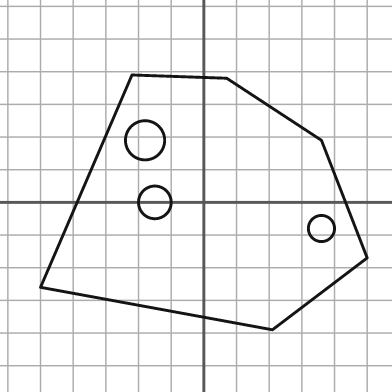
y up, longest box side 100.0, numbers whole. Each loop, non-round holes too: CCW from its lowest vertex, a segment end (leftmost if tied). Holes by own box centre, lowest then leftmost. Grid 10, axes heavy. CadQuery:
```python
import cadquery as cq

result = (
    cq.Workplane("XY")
    .moveTo(21.0, -39.0)
    .lineTo(50.0, -17.0)
    .lineTo(36.0, 19.0)
    .lineTo(7.0, 38.0)
    .lineTo(-22.0, 39.0)
    .lineTo(-50.0, -26.0)
    .close()
    .moveTo(36.0, -8.0)
    .circle(4.0)
    .moveTo(-15.0, 0.0)
    .circle(5.0)
    .moveTo(-18.0, 19.0)
    .circle(6.0)
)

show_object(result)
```